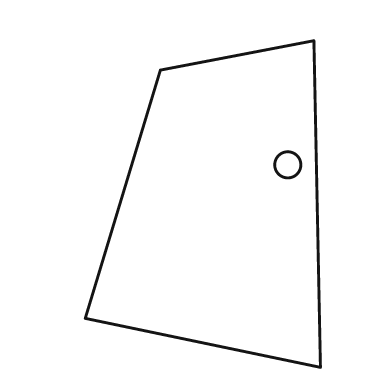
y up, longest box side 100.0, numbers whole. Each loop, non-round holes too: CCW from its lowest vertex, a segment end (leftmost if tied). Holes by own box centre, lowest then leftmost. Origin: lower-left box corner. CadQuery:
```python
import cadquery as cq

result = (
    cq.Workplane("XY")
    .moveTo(72.0, 0.0)
    .lineTo(70.0, 100.0)
    .lineTo(23.0, 91.0)
    .lineTo(0.0, 15.0)
    .close()
    .moveTo(62.0, 62.0)
    .circle(4.0)
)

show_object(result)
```